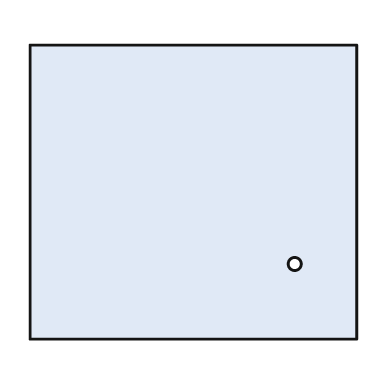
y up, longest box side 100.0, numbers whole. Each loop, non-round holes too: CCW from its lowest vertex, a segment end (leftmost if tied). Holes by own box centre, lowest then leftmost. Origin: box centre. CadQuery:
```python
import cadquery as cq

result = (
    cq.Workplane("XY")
    .moveTo(-50.0, -45.0)
    .lineTo(50.0, -45.0)
    .lineTo(50.0, 45.0)
    .lineTo(-50.0, 45.0)
    .close()
    .moveTo(31.0, -22.0)
    .circle(2.0)
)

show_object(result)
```